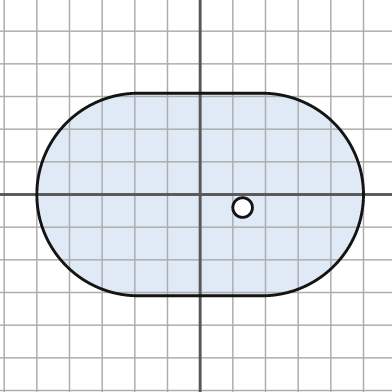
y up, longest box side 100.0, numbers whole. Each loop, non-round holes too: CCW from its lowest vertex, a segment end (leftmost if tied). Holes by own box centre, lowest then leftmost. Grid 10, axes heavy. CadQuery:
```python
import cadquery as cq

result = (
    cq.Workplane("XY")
    .moveTo(-19.0, -31.0)
    .lineTo(19.0, -31.0)
    .threePointArc((50.0, 0.0), (19.0, 31.0))
    .lineTo(-19.0, 31.0)
    .threePointArc((-50.0, 0.0), (-19.0, -31.0))
    .close()
    .moveTo(13.0, -4.0)
    .circle(3.0)
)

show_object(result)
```